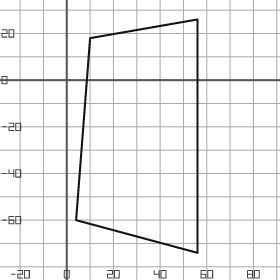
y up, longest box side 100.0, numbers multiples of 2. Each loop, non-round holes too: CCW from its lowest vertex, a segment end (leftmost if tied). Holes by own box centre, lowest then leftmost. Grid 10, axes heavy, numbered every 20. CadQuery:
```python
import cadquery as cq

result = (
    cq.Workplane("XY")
    .moveTo(56.0, -74.0)
    .lineTo(56.0, 26.0)
    .lineTo(10.0, 18.0)
    .lineTo(4.0, -60.0)
    .close()
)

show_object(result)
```